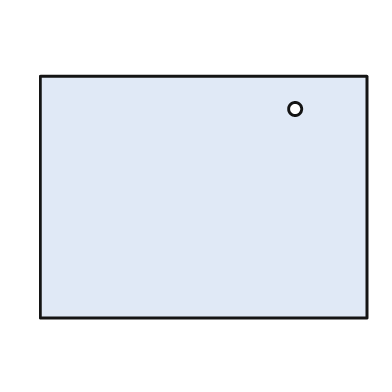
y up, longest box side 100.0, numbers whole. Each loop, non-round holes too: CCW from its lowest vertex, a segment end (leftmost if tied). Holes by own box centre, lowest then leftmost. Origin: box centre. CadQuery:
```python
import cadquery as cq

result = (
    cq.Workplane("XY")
    .moveTo(-50.0, -37.0)
    .lineTo(50.0, -37.0)
    .lineTo(50.0, 37.0)
    .lineTo(-50.0, 37.0)
    .close()
    .moveTo(28.0, 27.0)
    .circle(2.0)
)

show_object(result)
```